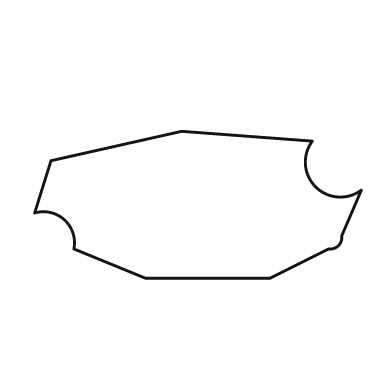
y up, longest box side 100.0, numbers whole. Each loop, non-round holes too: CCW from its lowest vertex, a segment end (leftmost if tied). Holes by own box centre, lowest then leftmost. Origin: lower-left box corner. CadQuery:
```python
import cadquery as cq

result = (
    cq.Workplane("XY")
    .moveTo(34.0, 0.0)
    .lineTo(72.0, 0.0)
    .lineTo(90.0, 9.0)
    .threePointArc((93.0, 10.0), (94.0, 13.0))
    .lineTo(100.0, 27.0)
    .threePointArc((86.0, 28.0), (85.0, 42.0))
    .lineTo(45.0, 45.0)
    .lineTo(5.0, 36.0)
    .lineTo(0.0, 20.0)
    .threePointArc((9.0, 18.0), (12.0, 9.0))
    .close()
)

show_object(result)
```